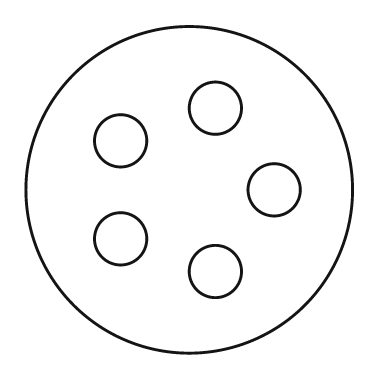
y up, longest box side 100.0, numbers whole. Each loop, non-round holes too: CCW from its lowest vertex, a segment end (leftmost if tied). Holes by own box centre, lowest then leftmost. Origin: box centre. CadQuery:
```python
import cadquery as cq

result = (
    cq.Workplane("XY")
    .moveTo(0.0, 0.0)
    .circle(50.0)
    .moveTo(8.0, -25.0)
    .circle(8.0)
    .moveTo(-21.0, -15.0)
    .circle(8.0)
    .moveTo(26.0, 0.0)
    .circle(8.0)
    .moveTo(-21.0, 15.0)
    .circle(8.0)
    .moveTo(8.0, 25.0)
    .circle(8.0)
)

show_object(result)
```